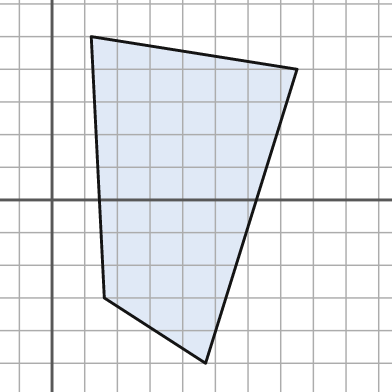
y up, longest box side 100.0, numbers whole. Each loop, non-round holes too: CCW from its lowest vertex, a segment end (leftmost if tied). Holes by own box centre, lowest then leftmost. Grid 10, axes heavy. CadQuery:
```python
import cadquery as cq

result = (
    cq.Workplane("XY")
    .moveTo(47.0, -50.0)
    .lineTo(75.0, 40.0)
    .lineTo(12.0, 50.0)
    .lineTo(16.0, -30.0)
    .close()
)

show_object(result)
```